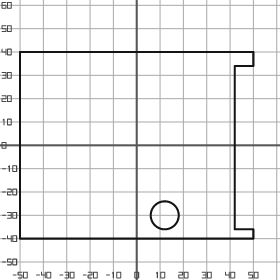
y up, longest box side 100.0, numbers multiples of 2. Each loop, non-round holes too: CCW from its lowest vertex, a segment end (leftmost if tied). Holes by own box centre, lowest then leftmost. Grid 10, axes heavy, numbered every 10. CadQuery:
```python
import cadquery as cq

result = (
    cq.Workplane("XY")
    .moveTo(-50.0, -40.0)
    .lineTo(50.0, -40.0)
    .lineTo(50.0, -36.0)
    .lineTo(42.0, -36.0)
    .lineTo(42.0, 34.0)
    .lineTo(50.0, 34.0)
    .lineTo(50.0, 40.0)
    .lineTo(-50.0, 40.0)
    .close()
    .moveTo(12.0, -30.0)
    .circle(6.0)
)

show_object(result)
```